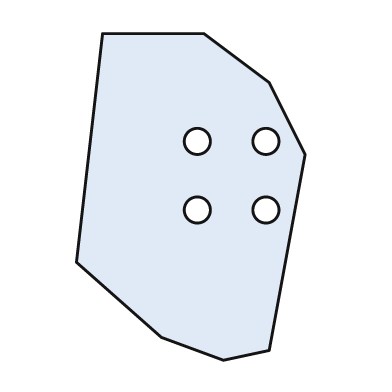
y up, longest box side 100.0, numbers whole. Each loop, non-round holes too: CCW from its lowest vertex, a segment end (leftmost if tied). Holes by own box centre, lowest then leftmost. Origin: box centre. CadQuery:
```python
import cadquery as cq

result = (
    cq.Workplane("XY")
    .moveTo(10.0, -50.0)
    .lineTo(24.0, -47.0)
    .lineTo(35.0, 13.0)
    .lineTo(24.0, 35.0)
    .lineTo(4.0, 50.0)
    .lineTo(-27.0, 50.0)
    .lineTo(-35.0, -20.0)
    .lineTo(-9.0, -43.0)
    .close()
    .moveTo(2.0, -4.0)
    .circle(4.0)
    .moveTo(23.0, -4.0)
    .circle(4.0)
    .moveTo(2.0, 17.0)
    .circle(4.0)
    .moveTo(23.0, 17.0)
    .circle(4.0)
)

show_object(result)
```